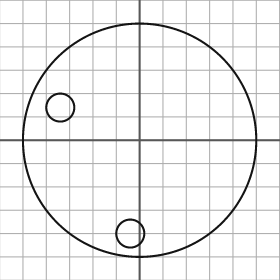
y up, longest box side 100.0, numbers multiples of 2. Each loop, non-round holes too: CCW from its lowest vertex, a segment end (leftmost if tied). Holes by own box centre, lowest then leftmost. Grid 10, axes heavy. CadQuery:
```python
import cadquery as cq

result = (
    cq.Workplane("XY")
    .moveTo(0.0, 0.0)
    .circle(50.0)
    .moveTo(-4.0, -40.0)
    .circle(6.0)
    .moveTo(-34.0, 14.0)
    .circle(6.0)
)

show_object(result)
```